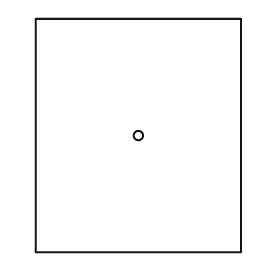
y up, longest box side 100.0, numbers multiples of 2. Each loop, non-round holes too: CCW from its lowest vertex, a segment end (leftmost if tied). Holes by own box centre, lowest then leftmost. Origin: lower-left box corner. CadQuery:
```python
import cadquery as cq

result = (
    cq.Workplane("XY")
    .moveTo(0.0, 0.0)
    .lineTo(88.0, 0.0)
    .lineTo(88.0, 100.0)
    .lineTo(0.0, 100.0)
    .close()
    .moveTo(44.0, 50.0)
    .circle(2.0)
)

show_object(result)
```